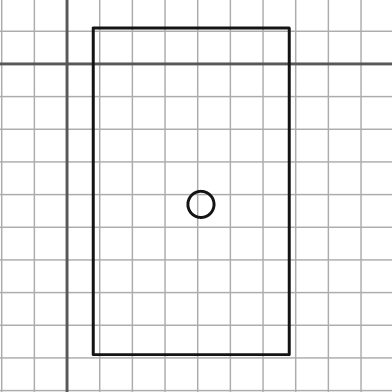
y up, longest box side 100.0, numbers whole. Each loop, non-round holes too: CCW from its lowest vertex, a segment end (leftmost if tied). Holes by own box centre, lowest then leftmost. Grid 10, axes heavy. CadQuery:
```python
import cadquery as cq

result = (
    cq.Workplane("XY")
    .moveTo(8.0, -89.0)
    .lineTo(68.0, -89.0)
    .lineTo(68.0, 11.0)
    .lineTo(8.0, 11.0)
    .close()
    .moveTo(41.0, -43.0)
    .circle(4.0)
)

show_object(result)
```